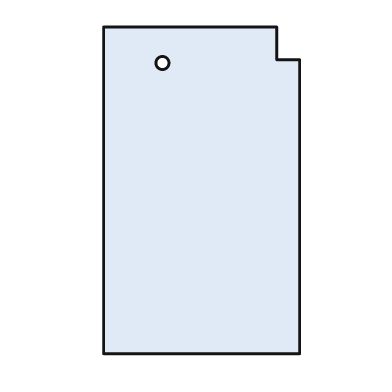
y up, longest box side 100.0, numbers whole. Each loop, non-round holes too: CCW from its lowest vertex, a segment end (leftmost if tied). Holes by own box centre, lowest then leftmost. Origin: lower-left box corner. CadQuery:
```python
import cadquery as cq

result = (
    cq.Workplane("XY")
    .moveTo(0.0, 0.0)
    .lineTo(60.0, 0.0)
    .lineTo(60.0, 90.0)
    .lineTo(53.0, 90.0)
    .lineTo(53.0, 100.0)
    .lineTo(0.0, 100.0)
    .close()
    .moveTo(18.0, 89.0)
    .circle(2.0)
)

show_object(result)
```